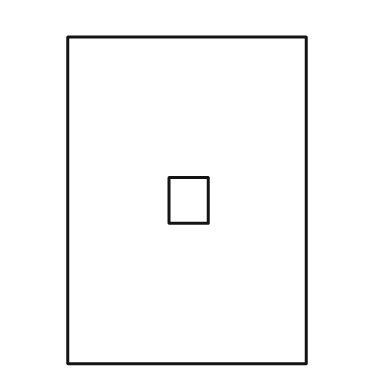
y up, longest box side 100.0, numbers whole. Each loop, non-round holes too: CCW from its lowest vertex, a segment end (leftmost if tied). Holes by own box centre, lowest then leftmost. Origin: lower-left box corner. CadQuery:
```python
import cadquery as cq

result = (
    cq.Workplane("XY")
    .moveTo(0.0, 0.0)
    .lineTo(73.0, 0.0)
    .lineTo(73.0, 100.0)
    .lineTo(0.0, 100.0)
    .close()
    .moveTo(31.0, 43.0)
    .lineTo(43.0, 43.0)
    .lineTo(43.0, 57.0)
    .lineTo(31.0, 57.0)
    .close()
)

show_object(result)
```